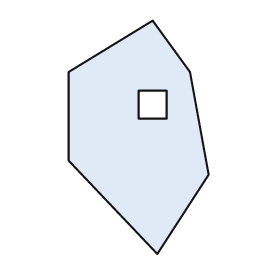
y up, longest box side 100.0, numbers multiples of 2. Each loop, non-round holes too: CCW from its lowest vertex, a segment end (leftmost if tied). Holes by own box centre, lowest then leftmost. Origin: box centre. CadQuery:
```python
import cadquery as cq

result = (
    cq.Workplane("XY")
    .moveTo(8.0, -50.0)
    .lineTo(30.0, -16.0)
    .lineTo(22.0, 28.0)
    .lineTo(6.0, 50.0)
    .lineTo(-30.0, 28.0)
    .lineTo(-30.0, -10.0)
    .close()
    .moveTo(0.0, 8.0)
    .lineTo(12.0, 8.0)
    .lineTo(12.0, 20.0)
    .lineTo(0.0, 20.0)
    .close()
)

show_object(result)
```